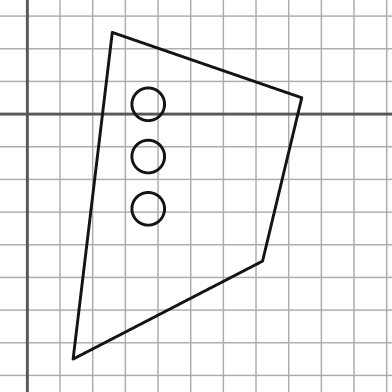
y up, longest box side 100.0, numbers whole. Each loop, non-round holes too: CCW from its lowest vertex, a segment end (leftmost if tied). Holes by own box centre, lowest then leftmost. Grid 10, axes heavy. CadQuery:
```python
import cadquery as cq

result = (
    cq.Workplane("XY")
    .moveTo(14.0, -75.0)
    .lineTo(72.0, -45.0)
    .lineTo(84.0, 5.0)
    .lineTo(26.0, 25.0)
    .close()
    .moveTo(37.0, -29.0)
    .circle(5.0)
    .moveTo(37.0, -13.0)
    .circle(5.0)
    .moveTo(37.0, 3.0)
    .circle(5.0)
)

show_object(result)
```